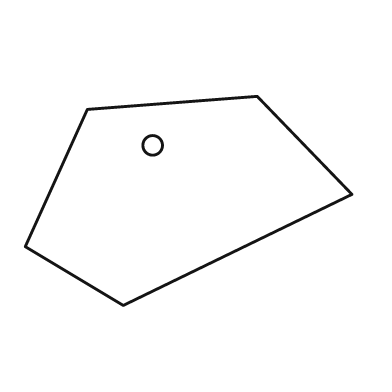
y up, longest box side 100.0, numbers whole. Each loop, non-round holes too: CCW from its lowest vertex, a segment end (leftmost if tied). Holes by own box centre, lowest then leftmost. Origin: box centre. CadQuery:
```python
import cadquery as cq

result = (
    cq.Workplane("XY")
    .moveTo(-20.0, -32.0)
    .lineTo(50.0, 2.0)
    .lineTo(21.0, 32.0)
    .lineTo(-31.0, 28.0)
    .lineTo(-50.0, -14.0)
    .close()
    .moveTo(-11.0, 17.0)
    .circle(3.0)
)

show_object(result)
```